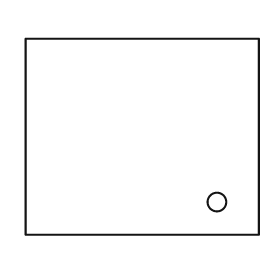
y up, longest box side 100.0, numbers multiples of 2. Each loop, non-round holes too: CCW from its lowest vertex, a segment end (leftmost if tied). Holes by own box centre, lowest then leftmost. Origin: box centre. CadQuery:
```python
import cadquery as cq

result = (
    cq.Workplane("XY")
    .moveTo(-50.0, -42.0)
    .lineTo(50.0, -42.0)
    .lineTo(50.0, 42.0)
    .lineTo(-50.0, 42.0)
    .close()
    .moveTo(32.0, -28.0)
    .circle(4.0)
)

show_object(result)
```